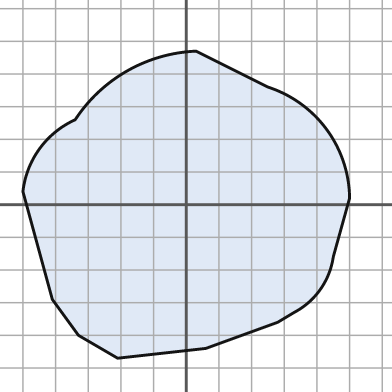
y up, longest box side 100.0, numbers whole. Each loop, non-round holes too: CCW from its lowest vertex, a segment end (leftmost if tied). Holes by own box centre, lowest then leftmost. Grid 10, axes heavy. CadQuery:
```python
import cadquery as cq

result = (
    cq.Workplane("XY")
    .moveTo(-21.0, -47.0)
    .lineTo(6.0, -44.0)
    .lineTo(28.0, -36.0)
    .lineTo(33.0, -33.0)
    .threePointArc((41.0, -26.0), (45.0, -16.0))
    .lineTo(50.0, 2.0)
    .threePointArc((43.0, 23.0), (25.0, 36.0))
    .lineTo(3.0, 47.0)
    .threePointArc((-18.0, 41.0), (-34.0, 26.0))
    .threePointArc((-45.0, 17.0), (-50.0, 4.0))
    .lineTo(-41.0, -29.0)
    .lineTo(-33.0, -40.0)
    .close()
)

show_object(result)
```